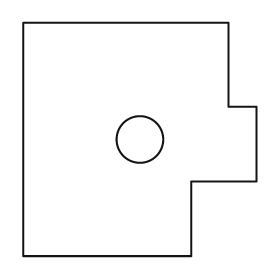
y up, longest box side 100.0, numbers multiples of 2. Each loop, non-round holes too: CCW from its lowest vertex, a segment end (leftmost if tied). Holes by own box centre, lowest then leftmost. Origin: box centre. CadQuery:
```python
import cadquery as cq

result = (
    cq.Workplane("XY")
    .moveTo(-50.0, -50.0)
    .lineTo(22.0, -50.0)
    .lineTo(22.0, -18.0)
    .lineTo(50.0, -18.0)
    .lineTo(50.0, 14.0)
    .lineTo(38.0, 14.0)
    .lineTo(38.0, 50.0)
    .lineTo(-50.0, 50.0)
    .close()
    .moveTo(0.0, 0.0)
    .circle(10.0)
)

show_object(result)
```